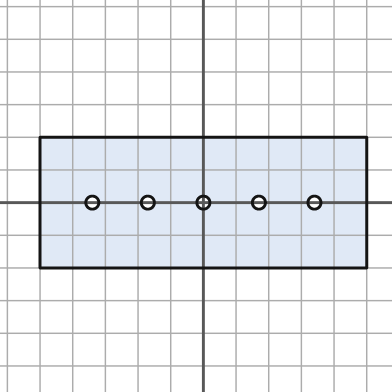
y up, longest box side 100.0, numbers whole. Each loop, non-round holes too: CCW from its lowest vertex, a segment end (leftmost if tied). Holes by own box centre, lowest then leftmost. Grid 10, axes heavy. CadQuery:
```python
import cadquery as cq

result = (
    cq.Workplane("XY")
    .moveTo(-50.0, -20.0)
    .lineTo(50.0, -20.0)
    .lineTo(50.0, 20.0)
    .lineTo(-50.0, 20.0)
    .close()
    .moveTo(-34.0, 0.0)
    .circle(2.0)
    .moveTo(-17.0, 0.0)
    .circle(2.0)
    .moveTo(0.0, 0.0)
    .circle(2.0)
    .moveTo(17.0, 0.0)
    .circle(2.0)
    .moveTo(34.0, 0.0)
    .circle(2.0)
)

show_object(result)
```